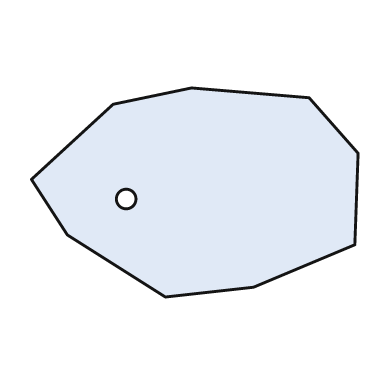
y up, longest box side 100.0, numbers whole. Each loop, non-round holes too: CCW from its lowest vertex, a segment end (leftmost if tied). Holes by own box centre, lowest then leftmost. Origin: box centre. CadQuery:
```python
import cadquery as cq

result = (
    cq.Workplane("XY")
    .moveTo(-9.0, -32.0)
    .lineTo(18.0, -29.0)
    .lineTo(49.0, -16.0)
    .lineTo(50.0, 12.0)
    .lineTo(35.0, 29.0)
    .lineTo(-1.0, 32.0)
    .lineTo(-25.0, 27.0)
    .lineTo(-50.0, 4.0)
    .lineTo(-39.0, -13.0)
    .close()
    .moveTo(-21.0, -2.0)
    .circle(3.0)
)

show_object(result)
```